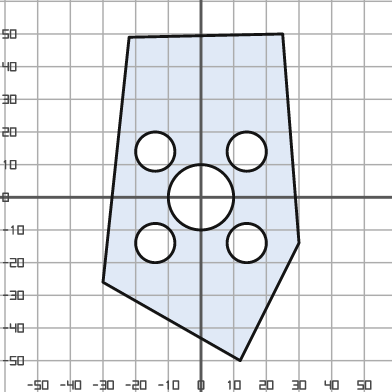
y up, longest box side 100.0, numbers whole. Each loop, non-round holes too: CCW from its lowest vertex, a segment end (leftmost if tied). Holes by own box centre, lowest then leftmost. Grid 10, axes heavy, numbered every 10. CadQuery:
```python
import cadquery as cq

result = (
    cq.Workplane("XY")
    .moveTo(12.0, -50.0)
    .lineTo(30.0, -14.0)
    .lineTo(25.0, 50.0)
    .lineTo(-22.0, 49.0)
    .lineTo(-30.0, -26.0)
    .close()
    .moveTo(-14.0, -14.0)
    .circle(6.0)
    .moveTo(14.0, -14.0)
    .circle(6.0)
    .moveTo(0.0, 0.0)
    .circle(10.0)
    .moveTo(-14.0, 14.0)
    .circle(6.0)
    .moveTo(14.0, 14.0)
    .circle(6.0)
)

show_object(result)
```